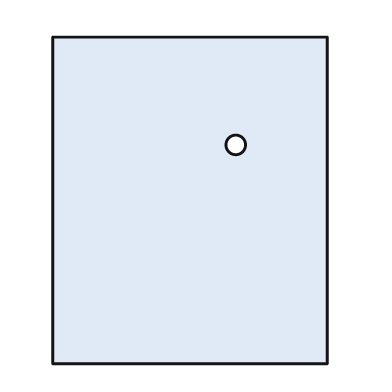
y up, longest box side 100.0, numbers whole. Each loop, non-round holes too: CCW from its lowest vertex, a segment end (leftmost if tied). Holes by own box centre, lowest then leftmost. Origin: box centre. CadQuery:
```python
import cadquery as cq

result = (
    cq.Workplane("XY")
    .moveTo(-42.0, -50.0)
    .lineTo(42.0, -50.0)
    .lineTo(42.0, 50.0)
    .lineTo(-42.0, 50.0)
    .close()
    .moveTo(14.0, 17.0)
    .circle(3.0)
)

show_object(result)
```